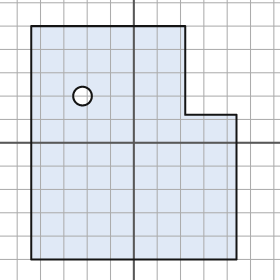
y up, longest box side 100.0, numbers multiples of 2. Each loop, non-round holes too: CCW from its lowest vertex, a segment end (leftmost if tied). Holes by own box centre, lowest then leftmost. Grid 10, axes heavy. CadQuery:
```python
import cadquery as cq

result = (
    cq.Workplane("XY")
    .moveTo(-44.0, -50.0)
    .lineTo(44.0, -50.0)
    .lineTo(44.0, 12.0)
    .lineTo(22.0, 12.0)
    .lineTo(22.0, 50.0)
    .lineTo(-44.0, 50.0)
    .close()
    .moveTo(-22.0, 20.0)
    .circle(4.0)
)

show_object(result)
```